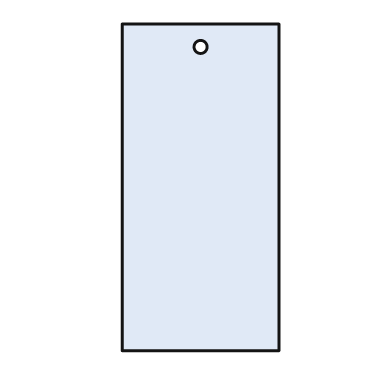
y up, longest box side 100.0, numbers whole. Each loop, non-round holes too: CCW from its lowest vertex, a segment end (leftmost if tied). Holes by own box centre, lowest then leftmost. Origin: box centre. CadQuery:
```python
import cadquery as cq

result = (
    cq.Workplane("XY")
    .moveTo(-24.0, -50.0)
    .lineTo(24.0, -50.0)
    .lineTo(24.0, 50.0)
    .lineTo(-24.0, 50.0)
    .close()
    .moveTo(0.0, 43.0)
    .circle(2.0)
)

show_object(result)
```